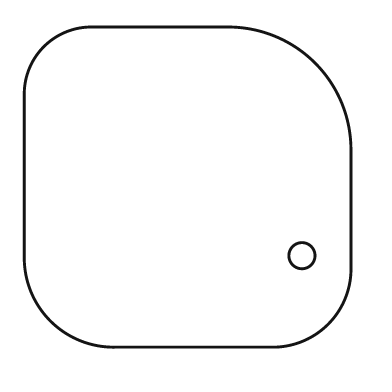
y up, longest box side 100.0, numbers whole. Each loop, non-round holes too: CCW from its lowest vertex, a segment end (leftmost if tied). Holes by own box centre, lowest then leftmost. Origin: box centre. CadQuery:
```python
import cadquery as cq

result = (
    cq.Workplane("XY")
    .moveTo(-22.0, -49.0)
    .lineTo(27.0, -49.0)
    .threePointArc((43.0, -42.0), (50.0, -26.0))
    .lineTo(50.0, 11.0)
    .threePointArc((39.0, 38.0), (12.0, 49.0))
    .lineTo(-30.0, 49.0)
    .threePointArc((-44.0, 43.0), (-50.0, 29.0))
    .lineTo(-50.0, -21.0)
    .threePointArc((-42.0, -41.0), (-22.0, -49.0))
    .close()
    .moveTo(35.0, -21.0)
    .circle(4.0)
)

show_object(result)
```